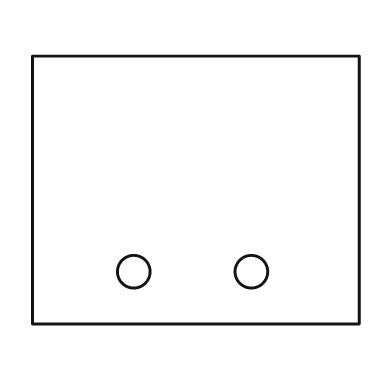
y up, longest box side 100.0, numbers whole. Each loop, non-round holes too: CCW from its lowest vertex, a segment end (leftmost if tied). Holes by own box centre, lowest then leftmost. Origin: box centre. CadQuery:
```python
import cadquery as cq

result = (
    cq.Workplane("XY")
    .moveTo(-50.0, -41.0)
    .lineTo(50.0, -41.0)
    .lineTo(50.0, 41.0)
    .lineTo(-50.0, 41.0)
    .close()
    .moveTo(-19.0, -25.0)
    .circle(5.0)
    .moveTo(17.0, -25.0)
    .circle(5.0)
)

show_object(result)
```